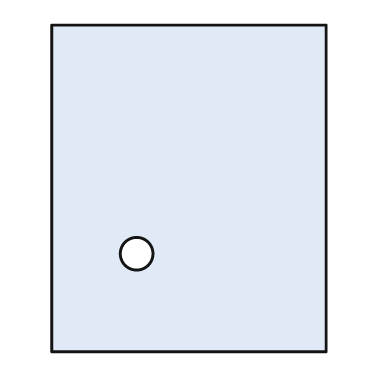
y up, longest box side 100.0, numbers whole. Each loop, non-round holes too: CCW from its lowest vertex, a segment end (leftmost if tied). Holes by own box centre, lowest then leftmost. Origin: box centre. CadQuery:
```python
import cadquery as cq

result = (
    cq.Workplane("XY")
    .moveTo(-42.0, -50.0)
    .lineTo(42.0, -50.0)
    .lineTo(42.0, 50.0)
    .lineTo(-42.0, 50.0)
    .close()
    .moveTo(-16.0, -20.0)
    .circle(5.0)
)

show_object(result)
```